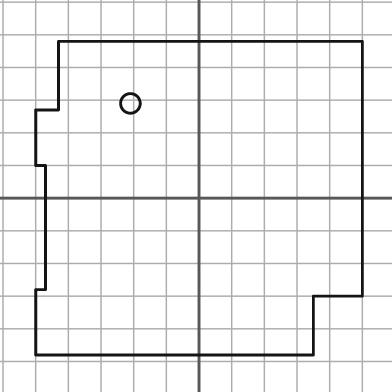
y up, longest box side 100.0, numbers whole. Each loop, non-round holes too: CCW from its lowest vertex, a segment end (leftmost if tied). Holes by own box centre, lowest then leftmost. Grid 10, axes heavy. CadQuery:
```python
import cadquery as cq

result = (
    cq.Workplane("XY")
    .moveTo(-50.0, -48.0)
    .lineTo(35.0, -48.0)
    .lineTo(35.0, -30.0)
    .lineTo(50.0, -30.0)
    .lineTo(50.0, 48.0)
    .lineTo(-43.0, 48.0)
    .lineTo(-43.0, 27.0)
    .lineTo(-50.0, 27.0)
    .lineTo(-50.0, 10.0)
    .lineTo(-47.0, 10.0)
    .lineTo(-47.0, -28.0)
    .lineTo(-50.0, -28.0)
    .close()
    .moveTo(-21.0, 29.0)
    .circle(3.0)
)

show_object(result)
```